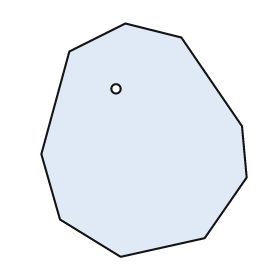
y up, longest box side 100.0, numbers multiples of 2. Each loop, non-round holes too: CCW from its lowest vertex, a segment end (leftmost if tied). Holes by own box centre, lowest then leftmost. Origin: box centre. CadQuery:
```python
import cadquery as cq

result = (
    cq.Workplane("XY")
    .moveTo(-10.0, -50.0)
    .lineTo(26.0, -42.0)
    .lineTo(44.0, -16.0)
    .lineTo(42.0, 6.0)
    .lineTo(16.0, 44.0)
    .lineTo(-8.0, 50.0)
    .lineTo(-32.0, 38.0)
    .lineTo(-44.0, -6.0)
    .lineTo(-36.0, -34.0)
    .close()
    .moveTo(-12.0, 22.0)
    .circle(2.0)
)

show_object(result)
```